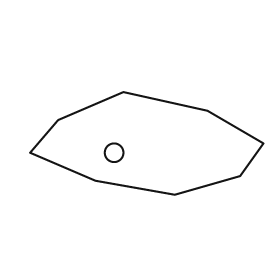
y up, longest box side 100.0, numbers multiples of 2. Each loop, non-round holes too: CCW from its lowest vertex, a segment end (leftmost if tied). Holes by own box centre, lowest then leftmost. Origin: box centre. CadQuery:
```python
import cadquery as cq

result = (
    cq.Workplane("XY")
    .moveTo(12.0, -22.0)
    .lineTo(40.0, -14.0)
    .lineTo(50.0, 0.0)
    .lineTo(26.0, 14.0)
    .lineTo(-10.0, 22.0)
    .lineTo(-38.0, 10.0)
    .lineTo(-50.0, -4.0)
    .lineTo(-22.0, -16.0)
    .close()
    .moveTo(-14.0, -4.0)
    .circle(4.0)
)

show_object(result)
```